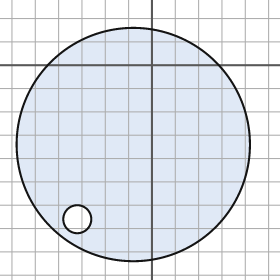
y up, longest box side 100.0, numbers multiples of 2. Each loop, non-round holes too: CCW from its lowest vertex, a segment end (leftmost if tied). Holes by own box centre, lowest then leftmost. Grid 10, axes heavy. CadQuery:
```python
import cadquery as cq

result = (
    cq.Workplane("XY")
    .moveTo(-8.0, -34.0)
    .circle(50.0)
    .moveTo(-32.0, -66.0)
    .circle(6.0)
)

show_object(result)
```